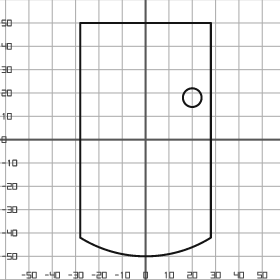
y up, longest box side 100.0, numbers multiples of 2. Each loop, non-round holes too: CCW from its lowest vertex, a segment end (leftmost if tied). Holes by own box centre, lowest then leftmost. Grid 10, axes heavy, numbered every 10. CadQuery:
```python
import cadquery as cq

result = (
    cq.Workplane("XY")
    .moveTo(-28.0, -42.0)
    .threePointArc((0.0, -50.0), (28.0, -42.0))
    .lineTo(28.0, 50.0)
    .lineTo(-28.0, 50.0)
    .close()
    .moveTo(20.0, 18.0)
    .circle(4.0)
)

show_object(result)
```